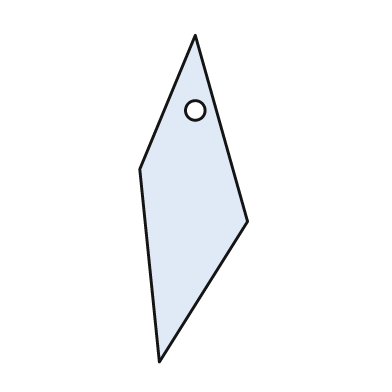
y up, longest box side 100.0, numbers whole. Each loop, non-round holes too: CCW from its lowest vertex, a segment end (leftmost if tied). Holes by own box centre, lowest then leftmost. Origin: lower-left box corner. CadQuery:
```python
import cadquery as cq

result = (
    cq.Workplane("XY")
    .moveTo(6.0, 0.0)
    .lineTo(33.0, 43.0)
    .lineTo(17.0, 100.0)
    .lineTo(0.0, 59.0)
    .close()
    .moveTo(17.0, 77.0)
    .circle(3.0)
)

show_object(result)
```